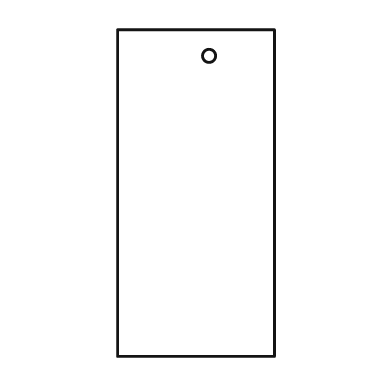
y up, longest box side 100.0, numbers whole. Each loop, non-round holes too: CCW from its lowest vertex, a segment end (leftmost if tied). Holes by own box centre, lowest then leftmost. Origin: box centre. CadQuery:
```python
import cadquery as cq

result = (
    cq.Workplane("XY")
    .moveTo(-24.0, -50.0)
    .lineTo(24.0, -50.0)
    .lineTo(24.0, 50.0)
    .lineTo(-24.0, 50.0)
    .close()
    .moveTo(4.0, 42.0)
    .circle(2.0)
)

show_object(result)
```